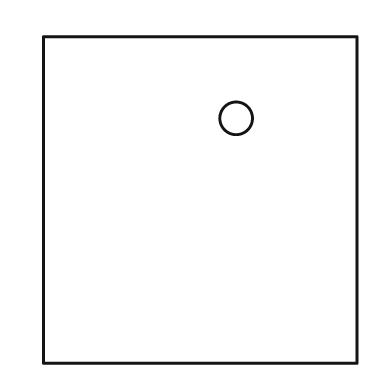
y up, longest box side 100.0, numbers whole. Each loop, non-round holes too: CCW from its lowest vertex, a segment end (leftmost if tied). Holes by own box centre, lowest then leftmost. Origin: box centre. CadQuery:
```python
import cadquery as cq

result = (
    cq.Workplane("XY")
    .moveTo(-48.0, -50.0)
    .lineTo(48.0, -50.0)
    .lineTo(48.0, 50.0)
    .lineTo(-48.0, 50.0)
    .close()
    .moveTo(11.0, 25.0)
    .circle(5.0)
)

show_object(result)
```